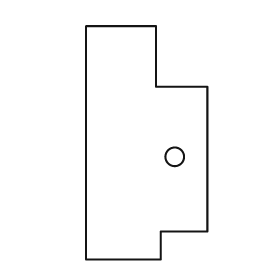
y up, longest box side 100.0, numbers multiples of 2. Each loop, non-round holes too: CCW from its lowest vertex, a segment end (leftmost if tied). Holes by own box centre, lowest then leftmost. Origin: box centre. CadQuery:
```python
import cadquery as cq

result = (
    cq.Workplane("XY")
    .moveTo(-26.0, -50.0)
    .lineTo(6.0, -50.0)
    .lineTo(6.0, -38.0)
    .lineTo(26.0, -38.0)
    .lineTo(26.0, 24.0)
    .lineTo(4.0, 24.0)
    .lineTo(4.0, 50.0)
    .lineTo(-26.0, 50.0)
    .close()
    .moveTo(12.0, -6.0)
    .circle(4.0)
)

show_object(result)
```